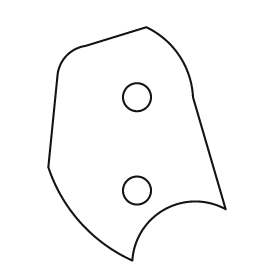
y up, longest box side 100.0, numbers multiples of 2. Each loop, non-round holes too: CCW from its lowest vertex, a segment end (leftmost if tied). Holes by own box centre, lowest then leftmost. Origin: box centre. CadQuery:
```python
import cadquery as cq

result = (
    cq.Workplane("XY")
    .moveTo(-2.0, -50.0)
    .threePointArc((12.0, -28.0), (38.0, -28.0))
    .lineTo(24.0, 20.0)
    .threePointArc((18.0, 38.0), (4.0, 50.0))
    .lineTo(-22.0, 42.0)
    .threePointArc((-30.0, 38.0), (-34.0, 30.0))
    .lineTo(-38.0, -10.0)
    .threePointArc((-24.0, -34.0), (-2.0, -50.0))
    .close()
    .moveTo(0.0, -20.0)
    .circle(6.0)
    .moveTo(0.0, 20.0)
    .circle(6.0)
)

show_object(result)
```